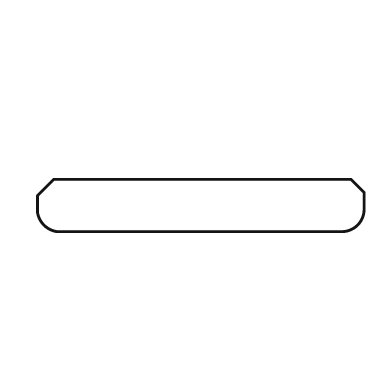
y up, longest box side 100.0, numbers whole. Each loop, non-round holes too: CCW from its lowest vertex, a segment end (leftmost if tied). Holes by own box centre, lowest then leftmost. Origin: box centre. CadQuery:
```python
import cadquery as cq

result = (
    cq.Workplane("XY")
    .moveTo(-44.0, -8.0)
    .lineTo(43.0, -8.0)
    .threePointArc((48.0, -6.0), (50.0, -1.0))
    .lineTo(50.0, 4.0)
    .lineTo(46.0, 8.0)
    .lineTo(-45.0, 8.0)
    .lineTo(-50.0, 3.0)
    .lineTo(-50.0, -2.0)
    .threePointArc((-48.0, -6.0), (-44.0, -8.0))
    .close()
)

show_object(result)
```